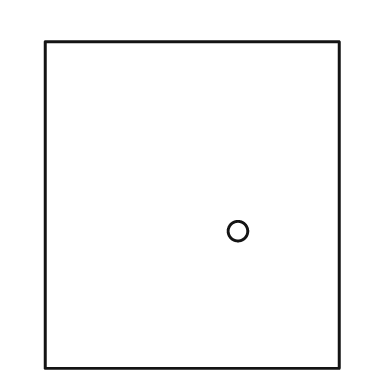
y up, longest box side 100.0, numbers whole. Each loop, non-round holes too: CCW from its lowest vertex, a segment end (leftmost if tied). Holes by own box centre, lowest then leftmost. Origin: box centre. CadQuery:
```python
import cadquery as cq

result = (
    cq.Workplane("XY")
    .moveTo(-45.0, -50.0)
    .lineTo(45.0, -50.0)
    .lineTo(45.0, 50.0)
    .lineTo(-45.0, 50.0)
    .close()
    .moveTo(14.0, -8.0)
    .circle(3.0)
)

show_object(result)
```